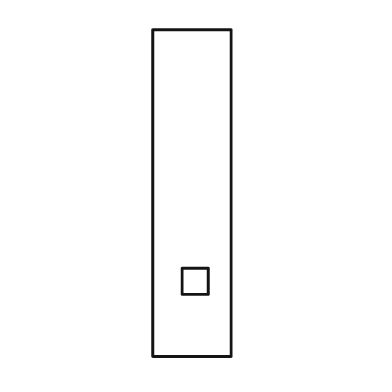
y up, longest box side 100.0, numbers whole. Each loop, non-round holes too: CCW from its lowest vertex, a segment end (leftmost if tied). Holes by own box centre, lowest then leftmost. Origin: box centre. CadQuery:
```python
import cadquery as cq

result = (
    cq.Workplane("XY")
    .moveTo(-12.0, -50.0)
    .lineTo(12.0, -50.0)
    .lineTo(12.0, 50.0)
    .lineTo(-12.0, 50.0)
    .close()
    .moveTo(-3.0, -31.0)
    .lineTo(5.0, -31.0)
    .lineTo(5.0, -23.0)
    .lineTo(-3.0, -23.0)
    .close()
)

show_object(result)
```